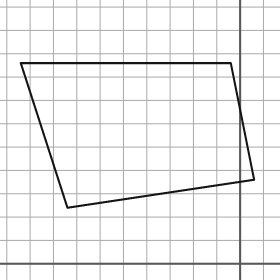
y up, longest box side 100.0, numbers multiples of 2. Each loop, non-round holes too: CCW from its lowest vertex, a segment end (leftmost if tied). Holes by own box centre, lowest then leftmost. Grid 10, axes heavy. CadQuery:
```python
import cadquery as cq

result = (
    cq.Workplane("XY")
    .moveTo(-74.0, 24.0)
    .lineTo(6.0, 36.0)
    .lineTo(-4.0, 86.0)
    .lineTo(-94.0, 86.0)
    .close()
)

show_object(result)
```